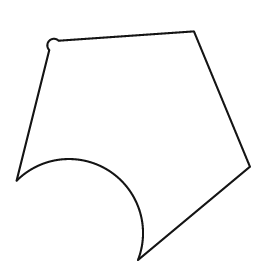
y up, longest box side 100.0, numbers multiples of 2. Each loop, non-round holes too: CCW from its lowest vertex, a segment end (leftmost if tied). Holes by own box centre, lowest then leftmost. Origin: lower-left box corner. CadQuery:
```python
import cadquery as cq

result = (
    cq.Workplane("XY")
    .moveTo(52.0, 0.0)
    .lineTo(100.0, 40.0)
    .lineTo(76.0, 98.0)
    .lineTo(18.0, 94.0)
    .threePointArc((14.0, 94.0), (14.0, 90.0))
    .lineTo(0.0, 34.0)
    .threePointArc((40.0, 38.0), (52.0, 0.0))
    .close()
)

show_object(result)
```